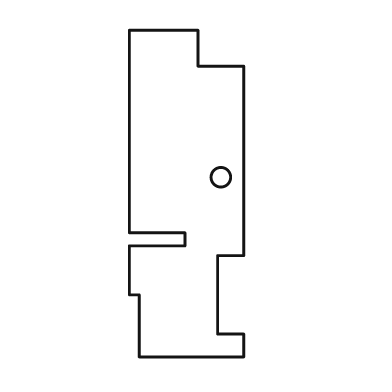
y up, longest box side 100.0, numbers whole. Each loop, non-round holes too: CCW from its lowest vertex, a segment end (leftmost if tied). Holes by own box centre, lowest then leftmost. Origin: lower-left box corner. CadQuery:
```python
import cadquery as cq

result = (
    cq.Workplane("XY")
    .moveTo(3.0, 0.0)
    .lineTo(35.0, 0.0)
    .lineTo(35.0, 7.0)
    .lineTo(27.0, 7.0)
    .lineTo(27.0, 31.0)
    .lineTo(35.0, 31.0)
    .lineTo(35.0, 89.0)
    .lineTo(21.0, 89.0)
    .lineTo(21.0, 100.0)
    .lineTo(0.0, 100.0)
    .lineTo(0.0, 38.0)
    .lineTo(17.0, 38.0)
    .lineTo(17.0, 34.0)
    .lineTo(0.0, 34.0)
    .lineTo(0.0, 19.0)
    .lineTo(3.0, 19.0)
    .close()
    .moveTo(28.0, 55.0)
    .circle(3.0)
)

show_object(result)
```